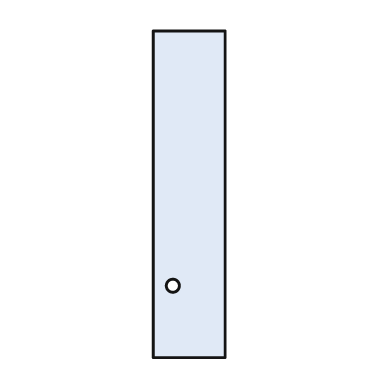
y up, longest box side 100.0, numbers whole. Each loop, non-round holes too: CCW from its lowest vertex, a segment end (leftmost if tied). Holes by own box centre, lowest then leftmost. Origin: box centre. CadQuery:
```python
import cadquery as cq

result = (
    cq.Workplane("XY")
    .moveTo(-11.0, -50.0)
    .lineTo(11.0, -50.0)
    .lineTo(11.0, 50.0)
    .lineTo(-11.0, 50.0)
    .close()
    .moveTo(-5.0, -28.0)
    .circle(2.0)
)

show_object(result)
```